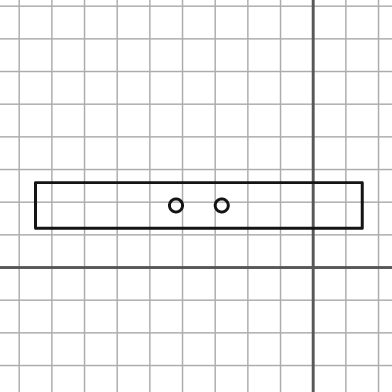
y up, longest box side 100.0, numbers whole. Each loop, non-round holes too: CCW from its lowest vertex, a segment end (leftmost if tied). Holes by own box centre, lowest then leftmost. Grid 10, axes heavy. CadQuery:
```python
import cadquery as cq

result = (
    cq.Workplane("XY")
    .moveTo(-85.0, 12.0)
    .lineTo(15.0, 12.0)
    .lineTo(15.0, 26.0)
    .lineTo(-85.0, 26.0)
    .close()
    .moveTo(-42.0, 19.0)
    .circle(2.0)
    .moveTo(-28.0, 19.0)
    .circle(2.0)
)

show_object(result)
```